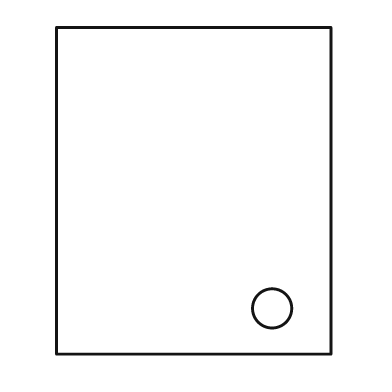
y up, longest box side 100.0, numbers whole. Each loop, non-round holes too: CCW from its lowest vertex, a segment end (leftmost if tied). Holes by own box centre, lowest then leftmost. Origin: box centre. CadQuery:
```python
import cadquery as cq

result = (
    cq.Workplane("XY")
    .moveTo(-42.0, -50.0)
    .lineTo(42.0, -50.0)
    .lineTo(42.0, 50.0)
    .lineTo(-42.0, 50.0)
    .close()
    .moveTo(24.0, -36.0)
    .circle(6.0)
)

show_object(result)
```